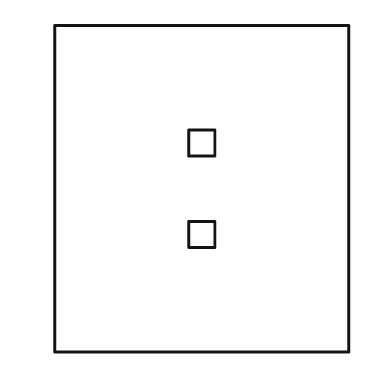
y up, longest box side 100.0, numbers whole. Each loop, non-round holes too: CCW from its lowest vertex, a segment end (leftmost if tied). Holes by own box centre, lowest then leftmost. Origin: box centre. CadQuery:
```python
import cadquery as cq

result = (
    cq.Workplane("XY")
    .moveTo(-45.0, -50.0)
    .lineTo(45.0, -50.0)
    .lineTo(45.0, 50.0)
    .lineTo(-45.0, 50.0)
    .close()
    .moveTo(-4.0, -18.0)
    .lineTo(4.0, -18.0)
    .lineTo(4.0, -10.0)
    .lineTo(-4.0, -10.0)
    .close()
    .moveTo(-4.0, 10.0)
    .lineTo(4.0, 10.0)
    .lineTo(4.0, 18.0)
    .lineTo(-4.0, 18.0)
    .close()
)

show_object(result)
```